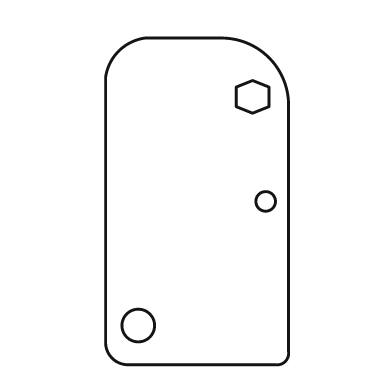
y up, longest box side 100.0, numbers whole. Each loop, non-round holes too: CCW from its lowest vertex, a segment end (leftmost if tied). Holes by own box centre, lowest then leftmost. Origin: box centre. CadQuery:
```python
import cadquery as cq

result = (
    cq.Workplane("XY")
    .moveTo(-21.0, -50.0)
    .lineTo(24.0, -50.0)
    .threePointArc((27.0, -49.0), (28.0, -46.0))
    .lineTo(28.0, 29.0)
    .threePointArc((22.0, 44.0), (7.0, 50.0))
    .lineTo(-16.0, 50.0)
    .threePointArc((-24.0, 46.0), (-28.0, 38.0))
    .lineTo(-28.0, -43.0)
    .threePointArc((-26.0, -48.0), (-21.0, -50.0))
    .close()
    .moveTo(-18.0, -38.0)
    .circle(5.0)
    .moveTo(21.0, 0.0)
    .circle(3.0)
    .moveTo(17.0, 27.0)
    .lineTo(22.0, 29.0)
    .lineTo(22.0, 35.0)
    .lineTo(17.0, 37.0)
    .lineTo(12.0, 35.0)
    .lineTo(12.0, 29.0)
    .close()
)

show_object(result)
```